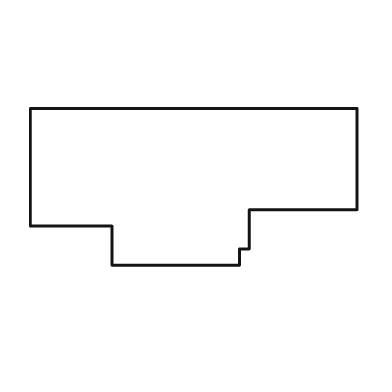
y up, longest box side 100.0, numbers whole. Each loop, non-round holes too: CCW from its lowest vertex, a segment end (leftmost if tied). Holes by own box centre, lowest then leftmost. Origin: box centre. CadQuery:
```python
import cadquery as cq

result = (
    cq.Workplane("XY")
    .moveTo(-25.0, -24.0)
    .lineTo(14.0, -24.0)
    .lineTo(14.0, -19.0)
    .lineTo(17.0, -19.0)
    .lineTo(17.0, -7.0)
    .lineTo(50.0, -7.0)
    .lineTo(50.0, 24.0)
    .lineTo(-50.0, 24.0)
    .lineTo(-50.0, -12.0)
    .lineTo(-25.0, -12.0)
    .close()
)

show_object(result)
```